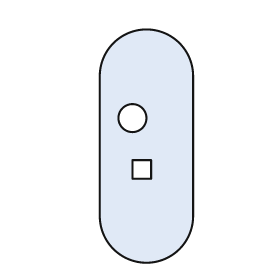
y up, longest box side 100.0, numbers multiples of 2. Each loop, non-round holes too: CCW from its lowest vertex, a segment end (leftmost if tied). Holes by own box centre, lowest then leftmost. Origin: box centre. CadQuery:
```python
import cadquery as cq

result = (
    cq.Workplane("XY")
    .moveTo(-20.0, -30.0)
    .threePointArc((0.0, -50.0), (20.0, -30.0))
    .lineTo(20.0, 30.0)
    .threePointArc((0.0, 50.0), (-20.0, 30.0))
    .close()
    .moveTo(-6.0, -14.0)
    .lineTo(2.0, -14.0)
    .lineTo(2.0, -6.0)
    .lineTo(-6.0, -6.0)
    .close()
    .moveTo(-6.0, 12.0)
    .circle(6.0)
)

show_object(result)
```